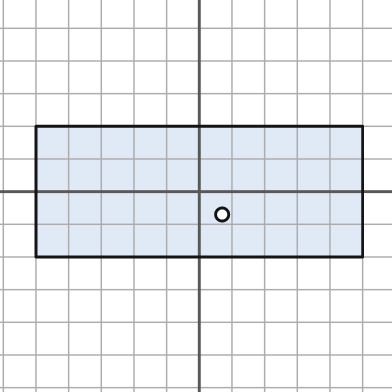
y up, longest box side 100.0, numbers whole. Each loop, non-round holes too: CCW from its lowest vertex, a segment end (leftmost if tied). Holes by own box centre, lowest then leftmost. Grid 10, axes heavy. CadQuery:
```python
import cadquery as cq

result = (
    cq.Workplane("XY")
    .moveTo(-50.0, -20.0)
    .lineTo(50.0, -20.0)
    .lineTo(50.0, 20.0)
    .lineTo(-50.0, 20.0)
    .close()
    .moveTo(7.0, -7.0)
    .circle(2.0)
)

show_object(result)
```